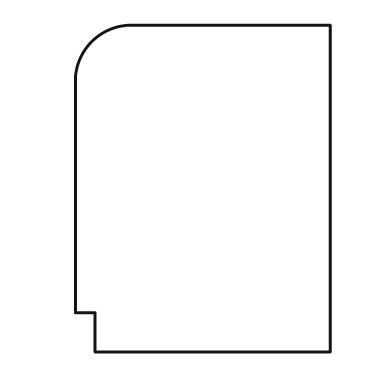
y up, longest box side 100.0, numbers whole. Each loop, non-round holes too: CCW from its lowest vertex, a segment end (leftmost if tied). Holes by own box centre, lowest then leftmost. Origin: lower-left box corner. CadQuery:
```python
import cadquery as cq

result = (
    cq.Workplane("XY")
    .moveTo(6.0, 0.0)
    .lineTo(78.0, 0.0)
    .lineTo(78.0, 100.0)
    .lineTo(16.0, 100.0)
    .threePointArc((5.0, 95.0), (0.0, 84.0))
    .lineTo(0.0, 12.0)
    .lineTo(6.0, 12.0)
    .close()
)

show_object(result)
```